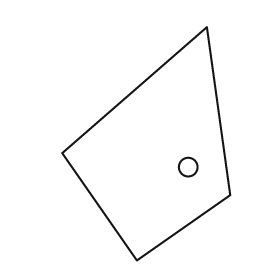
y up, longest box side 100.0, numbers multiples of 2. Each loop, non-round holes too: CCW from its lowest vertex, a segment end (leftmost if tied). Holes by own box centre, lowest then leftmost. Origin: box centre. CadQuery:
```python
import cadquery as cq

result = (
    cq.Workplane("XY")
    .moveTo(-4.0, -50.0)
    .lineTo(36.0, -22.0)
    .lineTo(26.0, 50.0)
    .lineTo(-36.0, -4.0)
    .close()
    .moveTo(18.0, -10.0)
    .circle(4.0)
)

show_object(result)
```